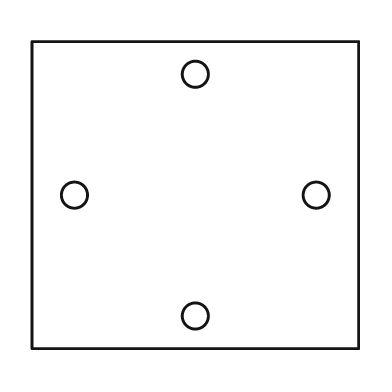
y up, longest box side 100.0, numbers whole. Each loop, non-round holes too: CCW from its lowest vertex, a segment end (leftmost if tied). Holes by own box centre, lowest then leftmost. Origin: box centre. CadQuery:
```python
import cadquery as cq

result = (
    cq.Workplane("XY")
    .moveTo(-50.0, -47.0)
    .lineTo(50.0, -47.0)
    .lineTo(50.0, 47.0)
    .lineTo(-50.0, 47.0)
    .close()
    .moveTo(0.0, -37.0)
    .circle(4.0)
    .moveTo(-37.0, 0.0)
    .circle(4.0)
    .moveTo(37.0, 0.0)
    .circle(4.0)
    .moveTo(0.0, 37.0)
    .circle(4.0)
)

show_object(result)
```